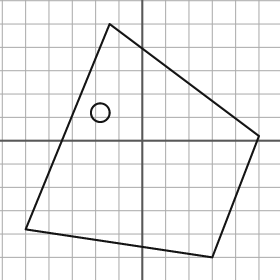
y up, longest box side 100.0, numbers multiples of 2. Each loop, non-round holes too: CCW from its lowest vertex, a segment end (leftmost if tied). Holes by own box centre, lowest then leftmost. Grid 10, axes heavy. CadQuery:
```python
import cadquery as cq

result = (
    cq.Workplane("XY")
    .moveTo(30.0, -50.0)
    .lineTo(50.0, 2.0)
    .lineTo(-14.0, 50.0)
    .lineTo(-50.0, -38.0)
    .close()
    .moveTo(-18.0, 12.0)
    .circle(4.0)
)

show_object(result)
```